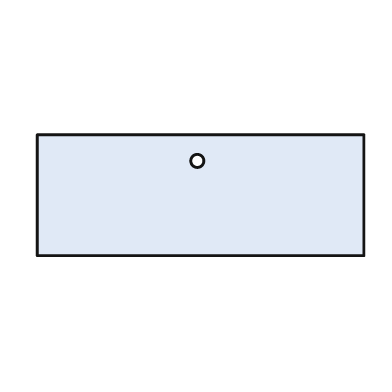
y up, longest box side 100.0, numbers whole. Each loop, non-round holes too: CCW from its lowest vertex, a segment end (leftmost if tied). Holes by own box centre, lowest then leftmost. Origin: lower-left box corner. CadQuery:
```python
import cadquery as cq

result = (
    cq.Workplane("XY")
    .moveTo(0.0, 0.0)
    .lineTo(100.0, 0.0)
    .lineTo(100.0, 37.0)
    .lineTo(0.0, 37.0)
    .close()
    .moveTo(49.0, 29.0)
    .circle(2.0)
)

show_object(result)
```